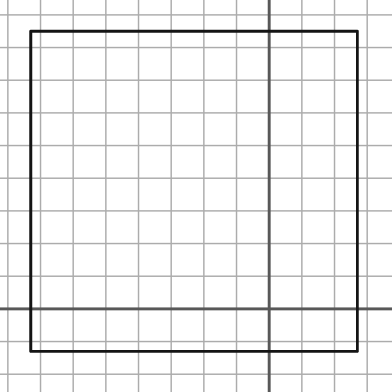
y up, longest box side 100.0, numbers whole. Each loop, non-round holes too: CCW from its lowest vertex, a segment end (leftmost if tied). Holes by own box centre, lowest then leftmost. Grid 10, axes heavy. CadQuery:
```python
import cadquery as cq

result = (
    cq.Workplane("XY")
    .moveTo(-73.0, -13.0)
    .lineTo(27.0, -13.0)
    .lineTo(27.0, 85.0)
    .lineTo(-73.0, 85.0)
    .close()
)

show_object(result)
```